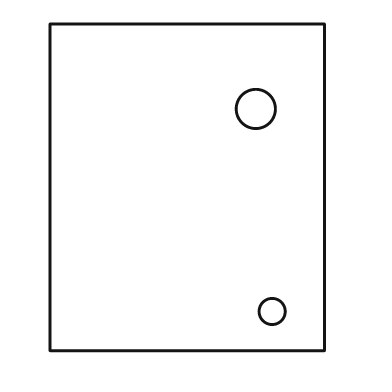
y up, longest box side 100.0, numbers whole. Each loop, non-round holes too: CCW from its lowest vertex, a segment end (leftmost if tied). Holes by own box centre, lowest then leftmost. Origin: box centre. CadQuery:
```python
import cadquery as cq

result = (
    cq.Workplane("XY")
    .moveTo(-42.0, -50.0)
    .lineTo(42.0, -50.0)
    .lineTo(42.0, 50.0)
    .lineTo(-42.0, 50.0)
    .close()
    .moveTo(26.0, -38.0)
    .circle(4.0)
    .moveTo(21.0, 24.0)
    .circle(6.0)
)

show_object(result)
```